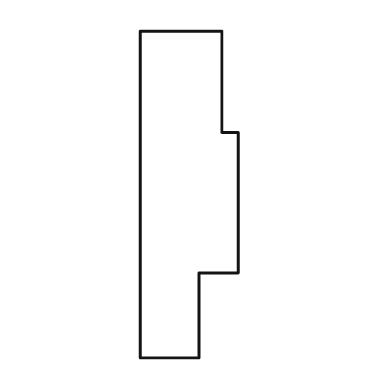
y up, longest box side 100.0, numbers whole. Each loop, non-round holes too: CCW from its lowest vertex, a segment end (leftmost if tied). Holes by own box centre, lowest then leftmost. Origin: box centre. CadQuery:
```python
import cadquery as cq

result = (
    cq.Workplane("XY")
    .moveTo(-15.0, -50.0)
    .lineTo(3.0, -50.0)
    .lineTo(3.0, -24.0)
    .lineTo(15.0, -24.0)
    .lineTo(15.0, 19.0)
    .lineTo(10.0, 19.0)
    .lineTo(10.0, 50.0)
    .lineTo(-15.0, 50.0)
    .close()
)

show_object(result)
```